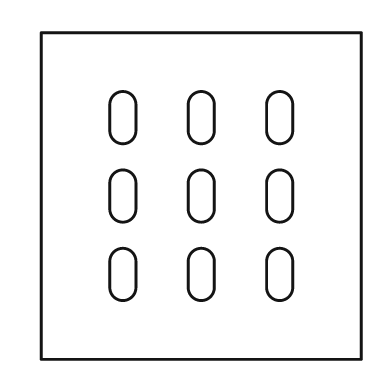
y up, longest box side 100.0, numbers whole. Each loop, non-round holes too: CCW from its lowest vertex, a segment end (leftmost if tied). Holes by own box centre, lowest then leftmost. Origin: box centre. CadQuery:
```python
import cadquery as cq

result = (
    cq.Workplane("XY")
    .moveTo(-49.0, -50.0)
    .lineTo(49.0, -50.0)
    .lineTo(49.0, 50.0)
    .lineTo(-49.0, 50.0)
    .close()
    .moveTo(-28.0, -28.0)
    .threePointArc((-24.0, -32.0), (-20.0, -28.0))
    .lineTo(-20.0, -20.0)
    .threePointArc((-24.0, -16.0), (-28.0, -20.0))
    .close()
    .moveTo(-4.0, -28.0)
    .threePointArc((0.0, -32.0), (4.0, -28.0))
    .lineTo(4.0, -20.0)
    .threePointArc((0.0, -16.0), (-4.0, -20.0))
    .close()
    .moveTo(20.0, -28.0)
    .threePointArc((24.0, -32.0), (28.0, -28.0))
    .lineTo(28.0, -20.0)
    .threePointArc((24.0, -16.0), (20.0, -20.0))
    .close()
    .moveTo(-28.0, -4.0)
    .threePointArc((-24.0, -8.0), (-20.0, -4.0))
    .lineTo(-20.0, 4.0)
    .threePointArc((-24.0, 8.0), (-28.0, 4.0))
    .close()
    .moveTo(-4.0, -4.0)
    .threePointArc((0.0, -8.0), (4.0, -4.0))
    .lineTo(4.0, 4.0)
    .threePointArc((0.0, 8.0), (-4.0, 4.0))
    .close()
    .moveTo(20.0, -4.0)
    .threePointArc((24.0, -8.0), (28.0, -4.0))
    .lineTo(28.0, 4.0)
    .threePointArc((24.0, 8.0), (20.0, 4.0))
    .close()
    .moveTo(-28.0, 20.0)
    .threePointArc((-24.0, 16.0), (-20.0, 20.0))
    .lineTo(-20.0, 28.0)
    .threePointArc((-24.0, 32.0), (-28.0, 28.0))
    .close()
    .moveTo(-4.0, 20.0)
    .threePointArc((0.0, 16.0), (4.0, 20.0))
    .lineTo(4.0, 28.0)
    .threePointArc((0.0, 32.0), (-4.0, 28.0))
    .close()
    .moveTo(20.0, 20.0)
    .threePointArc((24.0, 16.0), (28.0, 20.0))
    .lineTo(28.0, 28.0)
    .threePointArc((24.0, 32.0), (20.0, 28.0))
    .close()
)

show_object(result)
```